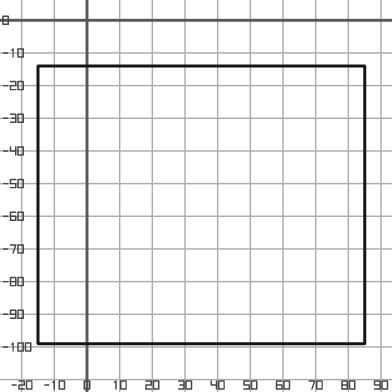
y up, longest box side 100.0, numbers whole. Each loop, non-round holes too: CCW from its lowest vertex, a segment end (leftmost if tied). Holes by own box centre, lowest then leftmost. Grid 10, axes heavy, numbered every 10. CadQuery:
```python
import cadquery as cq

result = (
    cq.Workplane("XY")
    .moveTo(-15.0, -99.0)
    .lineTo(85.0, -99.0)
    .lineTo(85.0, -14.0)
    .lineTo(-15.0, -14.0)
    .close()
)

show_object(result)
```